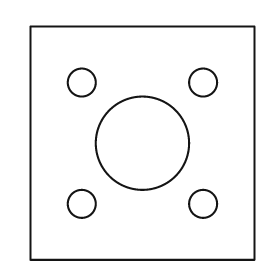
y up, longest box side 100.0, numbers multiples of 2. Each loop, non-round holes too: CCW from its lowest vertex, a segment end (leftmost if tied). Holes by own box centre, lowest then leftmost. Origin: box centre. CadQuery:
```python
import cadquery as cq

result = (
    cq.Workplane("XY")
    .moveTo(-48.0, -50.0)
    .lineTo(48.0, -50.0)
    .lineTo(48.0, 50.0)
    .lineTo(-48.0, 50.0)
    .close()
    .moveTo(-26.0, -26.0)
    .circle(6.0)
    .moveTo(26.0, -26.0)
    .circle(6.0)
    .moveTo(0.0, 0.0)
    .circle(20.0)
    .moveTo(-26.0, 26.0)
    .circle(6.0)
    .moveTo(26.0, 26.0)
    .circle(6.0)
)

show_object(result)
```